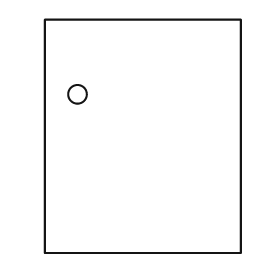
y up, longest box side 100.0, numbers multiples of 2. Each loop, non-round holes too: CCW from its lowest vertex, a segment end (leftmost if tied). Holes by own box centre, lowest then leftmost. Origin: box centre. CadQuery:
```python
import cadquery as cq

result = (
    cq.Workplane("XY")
    .moveTo(-42.0, -50.0)
    .lineTo(42.0, -50.0)
    .lineTo(42.0, 50.0)
    .lineTo(-42.0, 50.0)
    .close()
    .moveTo(-28.0, 18.0)
    .circle(4.0)
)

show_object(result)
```